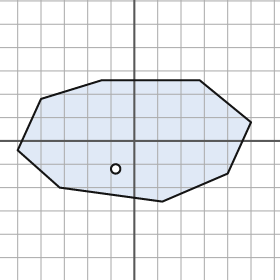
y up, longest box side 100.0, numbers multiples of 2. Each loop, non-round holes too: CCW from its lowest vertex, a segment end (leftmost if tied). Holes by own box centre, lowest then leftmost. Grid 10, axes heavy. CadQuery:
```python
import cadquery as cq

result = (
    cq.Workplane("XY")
    .moveTo(12.0, -26.0)
    .lineTo(40.0, -14.0)
    .lineTo(50.0, 8.0)
    .lineTo(28.0, 26.0)
    .lineTo(-14.0, 26.0)
    .lineTo(-40.0, 18.0)
    .lineTo(-50.0, -4.0)
    .lineTo(-32.0, -20.0)
    .close()
    .moveTo(-8.0, -12.0)
    .circle(2.0)
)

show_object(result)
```